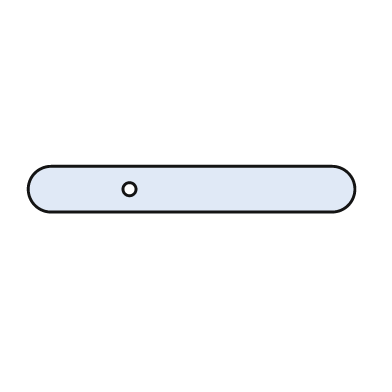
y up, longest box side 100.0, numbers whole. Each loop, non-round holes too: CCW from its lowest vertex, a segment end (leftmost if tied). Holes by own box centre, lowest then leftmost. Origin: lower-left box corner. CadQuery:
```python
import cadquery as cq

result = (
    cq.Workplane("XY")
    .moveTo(7.0, 0.0)
    .lineTo(93.0, 0.0)
    .threePointArc((100.0, 7.0), (93.0, 14.0))
    .lineTo(7.0, 14.0)
    .threePointArc((0.0, 7.0), (7.0, 0.0))
    .close()
    .moveTo(31.0, 7.0)
    .circle(2.0)
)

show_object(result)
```